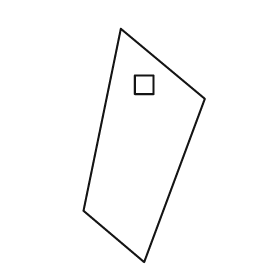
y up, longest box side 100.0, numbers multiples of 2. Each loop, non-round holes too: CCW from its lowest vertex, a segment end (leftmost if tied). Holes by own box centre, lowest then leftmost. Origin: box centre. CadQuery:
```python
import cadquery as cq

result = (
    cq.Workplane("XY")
    .moveTo(0.0, -50.0)
    .lineTo(26.0, 20.0)
    .lineTo(-10.0, 50.0)
    .lineTo(-26.0, -28.0)
    .close()
    .moveTo(-4.0, 22.0)
    .lineTo(4.0, 22.0)
    .lineTo(4.0, 30.0)
    .lineTo(-4.0, 30.0)
    .close()
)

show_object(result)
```